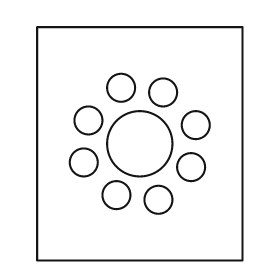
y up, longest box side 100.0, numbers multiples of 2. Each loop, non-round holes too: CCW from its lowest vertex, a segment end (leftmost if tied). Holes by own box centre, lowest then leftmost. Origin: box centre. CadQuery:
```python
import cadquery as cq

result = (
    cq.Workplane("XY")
    .moveTo(-44.0, -50.0)
    .lineTo(44.0, -50.0)
    .lineTo(44.0, 50.0)
    .lineTo(-44.0, 50.0)
    .close()
    .moveTo(8.0, -24.0)
    .circle(6.0)
    .moveTo(-10.0, -22.0)
    .circle(6.0)
    .moveTo(22.0, -10.0)
    .circle(6.0)
    .moveTo(-24.0, -8.0)
    .circle(6.0)
    .moveTo(0.0, 0.0)
    .circle(14.0)
    .moveTo(24.0, 8.0)
    .circle(6.0)
    .moveTo(-22.0, 10.0)
    .circle(6.0)
    .moveTo(10.0, 22.0)
    .circle(6.0)
    .moveTo(-8.0, 24.0)
    .circle(6.0)
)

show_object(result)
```